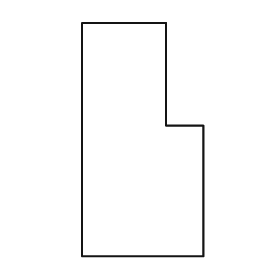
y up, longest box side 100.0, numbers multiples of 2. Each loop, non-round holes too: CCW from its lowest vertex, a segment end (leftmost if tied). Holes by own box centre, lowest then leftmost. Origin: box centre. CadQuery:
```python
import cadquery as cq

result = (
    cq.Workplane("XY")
    .moveTo(-26.0, -50.0)
    .lineTo(26.0, -50.0)
    .lineTo(26.0, 6.0)
    .lineTo(10.0, 6.0)
    .lineTo(10.0, 50.0)
    .lineTo(-26.0, 50.0)
    .close()
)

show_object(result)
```